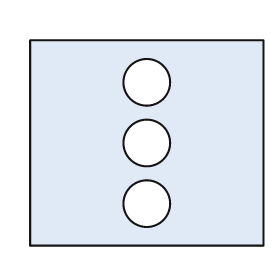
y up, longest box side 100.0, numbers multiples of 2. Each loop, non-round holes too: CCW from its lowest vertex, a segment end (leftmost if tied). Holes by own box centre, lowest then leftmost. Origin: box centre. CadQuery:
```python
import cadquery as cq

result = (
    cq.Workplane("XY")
    .moveTo(-50.0, -44.0)
    .lineTo(50.0, -44.0)
    .lineTo(50.0, 44.0)
    .lineTo(-50.0, 44.0)
    .close()
    .moveTo(0.0, -26.0)
    .circle(10.0)
    .moveTo(0.0, 0.0)
    .circle(10.0)
    .moveTo(0.0, 26.0)
    .circle(10.0)
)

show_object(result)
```